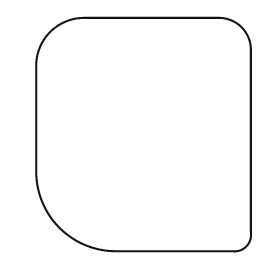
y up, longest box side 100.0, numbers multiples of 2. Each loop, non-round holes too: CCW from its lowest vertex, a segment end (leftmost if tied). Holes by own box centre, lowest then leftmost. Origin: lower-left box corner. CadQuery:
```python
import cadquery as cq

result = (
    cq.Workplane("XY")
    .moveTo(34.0, 0.0)
    .lineTo(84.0, 0.0)
    .threePointArc((90.0, 2.0), (92.0, 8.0))
    .lineTo(92.0, 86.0)
    .threePointArc((88.0, 96.0), (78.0, 100.0))
    .lineTo(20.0, 100.0)
    .threePointArc((6.0, 94.0), (0.0, 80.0))
    .lineTo(0.0, 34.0)
    .threePointArc((10.0, 10.0), (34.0, 0.0))
    .close()
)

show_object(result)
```